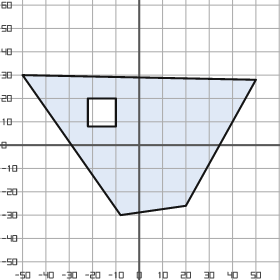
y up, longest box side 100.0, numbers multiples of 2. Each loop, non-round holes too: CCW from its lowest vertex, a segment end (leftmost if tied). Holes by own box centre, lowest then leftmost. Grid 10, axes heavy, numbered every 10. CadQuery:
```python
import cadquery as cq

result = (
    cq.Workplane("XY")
    .moveTo(-8.0, -30.0)
    .lineTo(20.0, -26.0)
    .lineTo(50.0, 28.0)
    .lineTo(-50.0, 30.0)
    .close()
    .moveTo(-22.0, 8.0)
    .lineTo(-10.0, 8.0)
    .lineTo(-10.0, 20.0)
    .lineTo(-22.0, 20.0)
    .close()
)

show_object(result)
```